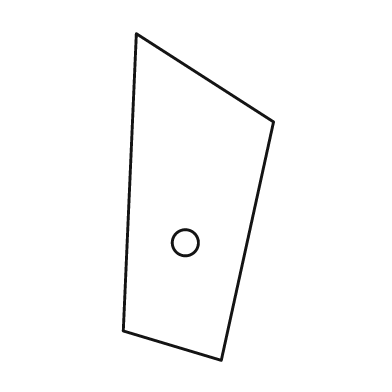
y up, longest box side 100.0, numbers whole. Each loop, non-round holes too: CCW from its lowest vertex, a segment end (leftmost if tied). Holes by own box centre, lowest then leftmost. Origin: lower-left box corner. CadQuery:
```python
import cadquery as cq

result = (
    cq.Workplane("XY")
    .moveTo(30.0, 0.0)
    .lineTo(46.0, 73.0)
    .lineTo(4.0, 100.0)
    .lineTo(0.0, 9.0)
    .close()
    .moveTo(19.0, 36.0)
    .circle(4.0)
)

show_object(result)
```